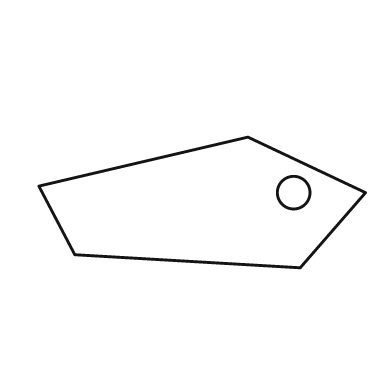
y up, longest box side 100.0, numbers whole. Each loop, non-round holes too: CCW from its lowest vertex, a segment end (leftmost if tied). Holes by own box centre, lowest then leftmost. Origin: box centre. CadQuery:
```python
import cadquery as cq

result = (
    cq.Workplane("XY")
    .moveTo(30.0, -20.0)
    .lineTo(50.0, 3.0)
    .lineTo(14.0, 20.0)
    .lineTo(-50.0, 5.0)
    .lineTo(-39.0, -16.0)
    .close()
    .moveTo(28.0, 3.0)
    .circle(5.0)
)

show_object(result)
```